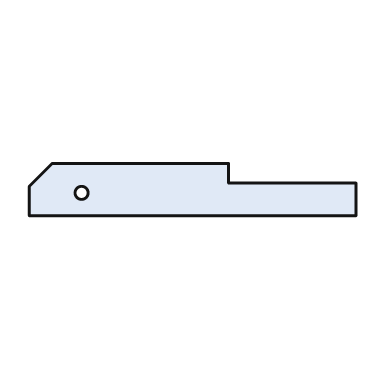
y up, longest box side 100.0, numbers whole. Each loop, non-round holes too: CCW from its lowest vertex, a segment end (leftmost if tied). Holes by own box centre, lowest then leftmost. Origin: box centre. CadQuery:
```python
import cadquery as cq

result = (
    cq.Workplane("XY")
    .moveTo(-50.0, -8.0)
    .lineTo(50.0, -8.0)
    .lineTo(50.0, 2.0)
    .lineTo(11.0, 2.0)
    .lineTo(11.0, 8.0)
    .lineTo(-43.0, 8.0)
    .lineTo(-50.0, 1.0)
    .close()
    .moveTo(-34.0, -1.0)
    .circle(2.0)
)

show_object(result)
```